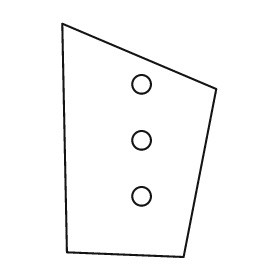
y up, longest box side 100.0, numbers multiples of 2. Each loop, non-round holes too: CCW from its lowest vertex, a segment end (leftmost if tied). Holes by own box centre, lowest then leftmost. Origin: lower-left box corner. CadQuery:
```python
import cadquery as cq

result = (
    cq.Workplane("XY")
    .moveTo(52.0, 0.0)
    .lineTo(66.0, 72.0)
    .lineTo(0.0, 100.0)
    .lineTo(2.0, 2.0)
    .close()
    .moveTo(34.0, 26.0)
    .circle(4.0)
    .moveTo(34.0, 50.0)
    .circle(4.0)
    .moveTo(34.0, 74.0)
    .circle(4.0)
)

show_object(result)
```